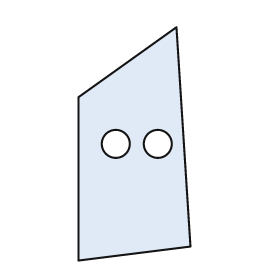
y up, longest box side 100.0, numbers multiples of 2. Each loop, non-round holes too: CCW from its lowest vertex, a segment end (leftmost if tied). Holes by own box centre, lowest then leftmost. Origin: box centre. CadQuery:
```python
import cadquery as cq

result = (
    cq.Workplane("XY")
    .moveTo(-24.0, -50.0)
    .lineTo(24.0, -44.0)
    .lineTo(18.0, 50.0)
    .lineTo(-24.0, 20.0)
    .close()
    .moveTo(-8.0, 0.0)
    .circle(6.0)
    .moveTo(10.0, 0.0)
    .circle(6.0)
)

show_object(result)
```